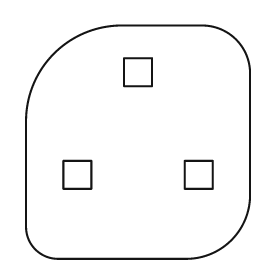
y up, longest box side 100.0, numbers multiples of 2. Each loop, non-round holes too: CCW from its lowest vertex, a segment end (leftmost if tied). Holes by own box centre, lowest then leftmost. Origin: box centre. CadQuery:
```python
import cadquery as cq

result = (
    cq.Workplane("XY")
    .moveTo(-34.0, -50.0)
    .lineTo(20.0, -50.0)
    .threePointArc((40.0, -42.0), (48.0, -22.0))
    .lineTo(48.0, 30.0)
    .threePointArc((42.0, 44.0), (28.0, 50.0))
    .lineTo(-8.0, 50.0)
    .threePointArc((-36.0, 38.0), (-48.0, 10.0))
    .lineTo(-48.0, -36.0)
    .threePointArc((-44.0, -46.0), (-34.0, -50.0))
    .close()
    .moveTo(-32.0, -20.0)
    .lineTo(-20.0, -20.0)
    .lineTo(-20.0, -8.0)
    .lineTo(-32.0, -8.0)
    .close()
    .moveTo(20.0, -20.0)
    .lineTo(32.0, -20.0)
    .lineTo(32.0, -8.0)
    .lineTo(20.0, -8.0)
    .close()
    .moveTo(-6.0, 24.0)
    .lineTo(6.0, 24.0)
    .lineTo(6.0, 36.0)
    .lineTo(-6.0, 36.0)
    .close()
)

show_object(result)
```